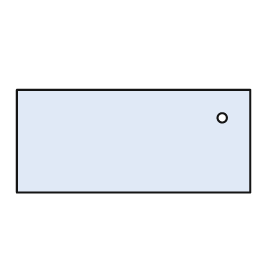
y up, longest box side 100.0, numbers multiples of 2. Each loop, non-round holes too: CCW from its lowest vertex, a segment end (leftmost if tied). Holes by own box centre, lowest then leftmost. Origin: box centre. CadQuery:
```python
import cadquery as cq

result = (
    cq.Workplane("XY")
    .moveTo(-50.0, -22.0)
    .lineTo(50.0, -22.0)
    .lineTo(50.0, 22.0)
    .lineTo(-50.0, 22.0)
    .close()
    .moveTo(38.0, 10.0)
    .circle(2.0)
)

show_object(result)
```